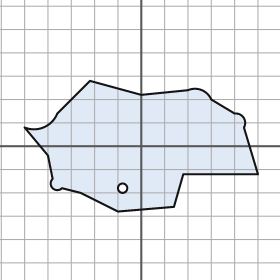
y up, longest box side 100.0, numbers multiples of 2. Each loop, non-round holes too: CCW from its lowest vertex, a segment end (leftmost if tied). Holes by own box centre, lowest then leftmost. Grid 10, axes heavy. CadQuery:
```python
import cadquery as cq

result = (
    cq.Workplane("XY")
    .moveTo(-10.0, -28.0)
    .lineTo(14.0, -26.0)
    .lineTo(18.0, -12.0)
    .lineTo(50.0, -12.0)
    .lineTo(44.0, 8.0)
    .threePointArc((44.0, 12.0), (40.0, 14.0))
    .lineTo(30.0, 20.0)
    .threePointArc((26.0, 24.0), (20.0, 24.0))
    .lineTo(0.0, 22.0)
    .lineTo(-22.0, 28.0)
    .lineTo(-36.0, 14.0)
    .threePointArc((-42.0, 8.0), (-50.0, 8.0))
    .lineTo(-40.0, -4.0)
    .lineTo(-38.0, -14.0)
    .threePointArc((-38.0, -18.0), (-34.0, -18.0))
    .lineTo(-26.0, -20.0)
    .close()
    .moveTo(-8.0, -18.0)
    .circle(2.0)
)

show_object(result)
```